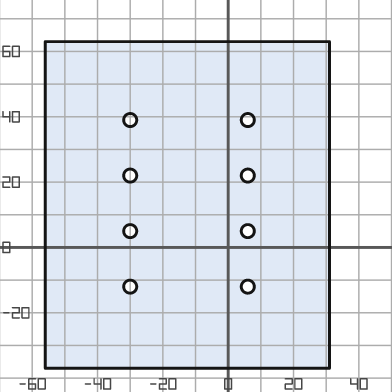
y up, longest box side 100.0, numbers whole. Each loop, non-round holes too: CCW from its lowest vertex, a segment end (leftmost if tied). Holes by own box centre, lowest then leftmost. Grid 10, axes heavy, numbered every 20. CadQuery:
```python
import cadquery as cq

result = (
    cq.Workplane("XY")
    .moveTo(-56.0, -37.0)
    .lineTo(31.0, -37.0)
    .lineTo(31.0, 63.0)
    .lineTo(-56.0, 63.0)
    .close()
    .moveTo(-30.0, -12.0)
    .circle(2.0)
    .moveTo(6.0, -12.0)
    .circle(2.0)
    .moveTo(-30.0, 5.0)
    .circle(2.0)
    .moveTo(6.0, 5.0)
    .circle(2.0)
    .moveTo(-30.0, 22.0)
    .circle(2.0)
    .moveTo(6.0, 22.0)
    .circle(2.0)
    .moveTo(-30.0, 39.0)
    .circle(2.0)
    .moveTo(6.0, 39.0)
    .circle(2.0)
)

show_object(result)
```